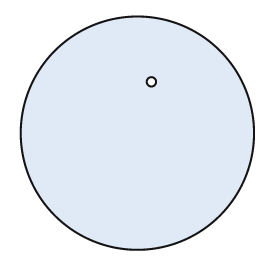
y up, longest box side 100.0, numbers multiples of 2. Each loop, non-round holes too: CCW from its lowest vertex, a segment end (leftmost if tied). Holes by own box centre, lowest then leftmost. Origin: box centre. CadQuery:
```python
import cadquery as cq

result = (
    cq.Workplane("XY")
    .moveTo(0.0, 0.0)
    .circle(50.0)
    .moveTo(6.0, 22.0)
    .circle(2.0)
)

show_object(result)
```